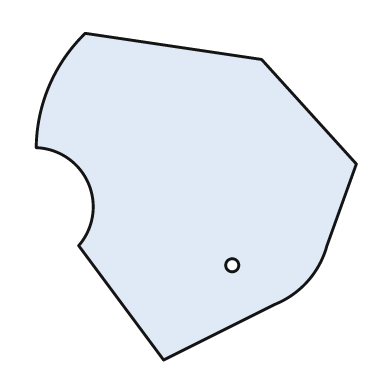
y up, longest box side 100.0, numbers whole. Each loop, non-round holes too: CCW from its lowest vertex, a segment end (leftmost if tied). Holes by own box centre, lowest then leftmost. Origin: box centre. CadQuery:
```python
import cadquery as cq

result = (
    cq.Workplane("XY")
    .moveTo(-10.0, -50.0)
    .lineTo(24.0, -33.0)
    .threePointArc((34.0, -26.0), (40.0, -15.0))
    .lineTo(49.0, 10.0)
    .lineTo(20.0, 42.0)
    .lineTo(-34.0, 50.0)
    .threePointArc((-45.0, 34.0), (-49.0, 15.0))
    .threePointArc((-33.0, 4.0), (-36.0, -15.0))
    .close()
    .moveTo(11.0, -21.0)
    .circle(2.0)
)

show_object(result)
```